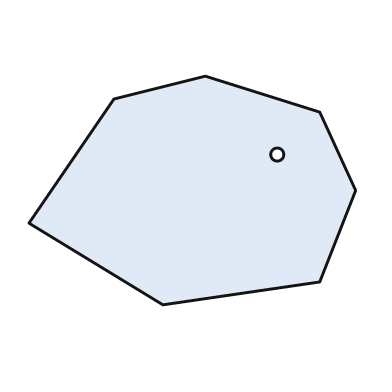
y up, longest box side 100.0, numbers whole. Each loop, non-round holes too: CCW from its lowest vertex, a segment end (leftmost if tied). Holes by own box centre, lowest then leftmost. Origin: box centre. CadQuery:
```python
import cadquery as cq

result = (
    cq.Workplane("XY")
    .moveTo(-9.0, -35.0)
    .lineTo(39.0, -28.0)
    .lineTo(50.0, 0.0)
    .lineTo(39.0, 24.0)
    .lineTo(4.0, 35.0)
    .lineTo(-24.0, 28.0)
    .lineTo(-50.0, -10.0)
    .close()
    .moveTo(26.0, 11.0)
    .circle(2.0)
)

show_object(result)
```